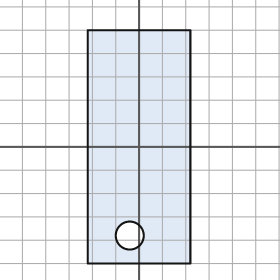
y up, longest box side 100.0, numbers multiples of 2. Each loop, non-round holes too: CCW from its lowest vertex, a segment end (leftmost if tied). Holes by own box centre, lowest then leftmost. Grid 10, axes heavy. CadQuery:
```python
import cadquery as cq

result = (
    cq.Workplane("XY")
    .moveTo(-22.0, -50.0)
    .lineTo(22.0, -50.0)
    .lineTo(22.0, 50.0)
    .lineTo(-22.0, 50.0)
    .close()
    .moveTo(-4.0, -38.0)
    .circle(6.0)
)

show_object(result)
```